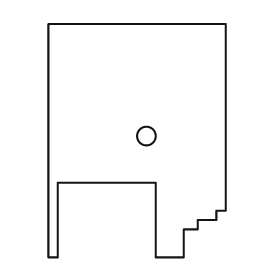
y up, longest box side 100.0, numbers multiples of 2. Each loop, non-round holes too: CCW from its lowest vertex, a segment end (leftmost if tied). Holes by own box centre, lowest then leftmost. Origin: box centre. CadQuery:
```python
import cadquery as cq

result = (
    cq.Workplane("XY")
    .moveTo(-38.0, -50.0)
    .lineTo(-34.0, -50.0)
    .lineTo(-34.0, -18.0)
    .lineTo(8.0, -18.0)
    .lineTo(8.0, -50.0)
    .lineTo(20.0, -50.0)
    .lineTo(20.0, -38.0)
    .lineTo(26.0, -38.0)
    .lineTo(26.0, -34.0)
    .lineTo(34.0, -34.0)
    .lineTo(34.0, -30.0)
    .lineTo(38.0, -30.0)
    .lineTo(38.0, 50.0)
    .lineTo(-38.0, 50.0)
    .close()
    .moveTo(4.0, 2.0)
    .circle(4.0)
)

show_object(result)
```